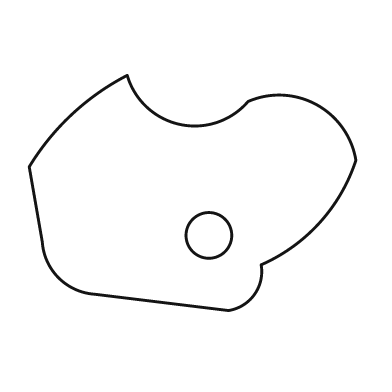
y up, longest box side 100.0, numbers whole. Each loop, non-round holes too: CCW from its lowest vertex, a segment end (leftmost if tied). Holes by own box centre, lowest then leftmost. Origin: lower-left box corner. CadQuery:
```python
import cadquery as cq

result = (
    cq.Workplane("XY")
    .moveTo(61.0, 0.0)
    .threePointArc((69.0, 5.0), (71.0, 14.0))
    .threePointArc((89.0, 27.0), (100.0, 46.0))
    .threePointArc((88.0, 63.0), (67.0, 64.0))
    .threePointArc((46.0, 57.0), (30.0, 72.0))
    .threePointArc((13.0, 60.0), (0.0, 44.0))
    .lineTo(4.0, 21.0)
    .threePointArc((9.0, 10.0), (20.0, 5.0))
    .close()
    .moveTo(55.0, 23.0)
    .circle(7.0)
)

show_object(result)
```